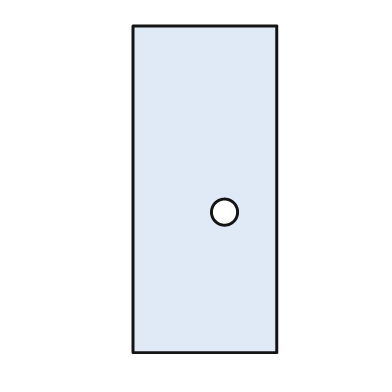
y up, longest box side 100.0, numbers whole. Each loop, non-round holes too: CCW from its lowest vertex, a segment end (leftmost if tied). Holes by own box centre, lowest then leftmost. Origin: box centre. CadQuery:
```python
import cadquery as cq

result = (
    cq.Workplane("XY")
    .moveTo(-22.0, -50.0)
    .lineTo(22.0, -50.0)
    .lineTo(22.0, 50.0)
    .lineTo(-22.0, 50.0)
    .close()
    .moveTo(6.0, -7.0)
    .circle(4.0)
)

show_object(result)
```